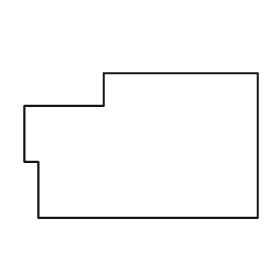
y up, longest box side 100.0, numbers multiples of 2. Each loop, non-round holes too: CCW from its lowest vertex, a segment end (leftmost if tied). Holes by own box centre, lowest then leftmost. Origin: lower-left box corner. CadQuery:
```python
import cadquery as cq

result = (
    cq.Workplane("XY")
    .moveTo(6.0, 0.0)
    .lineTo(100.0, 0.0)
    .lineTo(100.0, 62.0)
    .lineTo(34.0, 62.0)
    .lineTo(34.0, 48.0)
    .lineTo(0.0, 48.0)
    .lineTo(0.0, 24.0)
    .lineTo(6.0, 24.0)
    .close()
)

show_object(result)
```